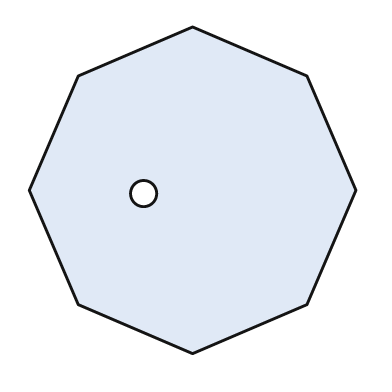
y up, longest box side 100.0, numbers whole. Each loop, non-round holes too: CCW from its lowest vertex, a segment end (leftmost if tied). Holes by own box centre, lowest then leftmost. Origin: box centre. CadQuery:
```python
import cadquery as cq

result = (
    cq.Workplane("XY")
    .moveTo(0.0, -50.0)
    .lineTo(35.0, -35.0)
    .lineTo(50.0, 0.0)
    .lineTo(35.0, 35.0)
    .lineTo(0.0, 50.0)
    .lineTo(-35.0, 35.0)
    .lineTo(-50.0, 0.0)
    .lineTo(-35.0, -35.0)
    .close()
    .moveTo(-15.0, -1.0)
    .circle(4.0)
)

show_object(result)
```